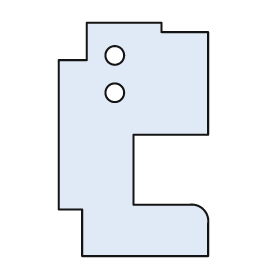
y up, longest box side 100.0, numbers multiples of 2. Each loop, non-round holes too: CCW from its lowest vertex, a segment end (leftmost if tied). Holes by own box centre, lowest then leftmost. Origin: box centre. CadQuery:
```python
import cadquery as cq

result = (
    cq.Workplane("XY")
    .moveTo(-22.0, -50.0)
    .lineTo(32.0, -50.0)
    .lineTo(32.0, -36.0)
    .threePointArc((30.0, -30.0), (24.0, -28.0))
    .lineTo(0.0, -28.0)
    .lineTo(0.0, 2.0)
    .lineTo(32.0, 2.0)
    .lineTo(32.0, 46.0)
    .lineTo(12.0, 46.0)
    .lineTo(12.0, 50.0)
    .lineTo(-20.0, 50.0)
    .lineTo(-20.0, 34.0)
    .lineTo(-32.0, 34.0)
    .lineTo(-32.0, -30.0)
    .lineTo(-22.0, -30.0)
    .close()
    .moveTo(-8.0, 20.0)
    .circle(4.0)
    .moveTo(-8.0, 36.0)
    .circle(4.0)
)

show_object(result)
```